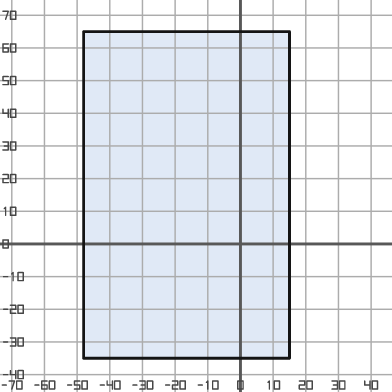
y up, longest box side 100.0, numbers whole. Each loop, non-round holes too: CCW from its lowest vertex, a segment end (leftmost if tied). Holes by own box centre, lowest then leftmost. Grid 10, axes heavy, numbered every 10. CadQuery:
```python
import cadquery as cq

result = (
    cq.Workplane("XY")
    .moveTo(-48.0, -35.0)
    .lineTo(15.0, -35.0)
    .lineTo(15.0, 65.0)
    .lineTo(-48.0, 65.0)
    .close()
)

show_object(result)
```